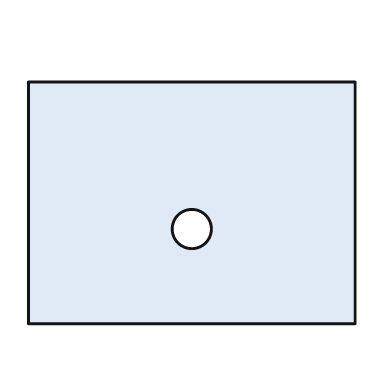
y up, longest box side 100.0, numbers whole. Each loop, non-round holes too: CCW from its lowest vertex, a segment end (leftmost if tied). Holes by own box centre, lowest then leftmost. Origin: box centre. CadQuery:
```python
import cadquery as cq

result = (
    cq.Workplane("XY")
    .moveTo(-50.0, -37.0)
    .lineTo(50.0, -37.0)
    .lineTo(50.0, 37.0)
    .lineTo(-50.0, 37.0)
    .close()
    .moveTo(0.0, -8.0)
    .circle(6.0)
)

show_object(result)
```